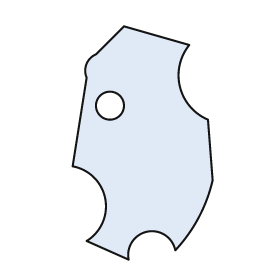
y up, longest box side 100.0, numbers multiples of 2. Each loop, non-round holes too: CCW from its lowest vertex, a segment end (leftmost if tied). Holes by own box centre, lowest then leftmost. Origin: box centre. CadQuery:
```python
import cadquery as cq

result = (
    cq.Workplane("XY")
    .moveTo(-6.0, -50.0)
    .threePointArc((2.0, -38.0), (14.0, -46.0))
    .threePointArc((24.0, -32.0), (30.0, -16.0))
    .lineTo(28.0, 10.0)
    .threePointArc((16.0, 24.0), (20.0, 42.0))
    .lineTo(-8.0, 50.0)
    .lineTo(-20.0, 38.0)
    .threePointArc((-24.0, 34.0), (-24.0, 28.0))
    .lineTo(-30.0, -10.0)
    .threePointArc((-16.0, -24.0), (-24.0, -42.0))
    .close()
    .moveTo(-14.0, 16.0)
    .circle(6.0)
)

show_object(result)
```